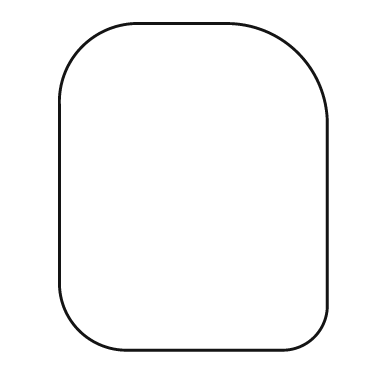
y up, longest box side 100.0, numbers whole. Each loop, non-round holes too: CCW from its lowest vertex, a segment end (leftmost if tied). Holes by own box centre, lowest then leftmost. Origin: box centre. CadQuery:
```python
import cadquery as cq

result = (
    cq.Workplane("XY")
    .moveTo(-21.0, -50.0)
    .lineTo(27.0, -50.0)
    .threePointArc((37.0, -46.0), (41.0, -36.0))
    .lineTo(41.0, 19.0)
    .threePointArc((32.0, 41.0), (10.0, 50.0))
    .lineTo(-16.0, 50.0)
    .threePointArc((-34.0, 43.0), (-41.0, 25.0))
    .lineTo(-41.0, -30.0)
    .threePointArc((-35.0, -44.0), (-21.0, -50.0))
    .close()
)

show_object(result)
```